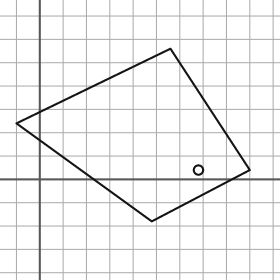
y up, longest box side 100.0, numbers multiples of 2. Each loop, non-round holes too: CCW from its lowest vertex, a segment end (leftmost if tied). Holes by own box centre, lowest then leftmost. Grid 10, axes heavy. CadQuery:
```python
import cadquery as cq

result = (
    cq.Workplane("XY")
    .moveTo(48.0, -18.0)
    .lineTo(90.0, 4.0)
    .lineTo(56.0, 56.0)
    .lineTo(-10.0, 24.0)
    .close()
    .moveTo(68.0, 4.0)
    .circle(2.0)
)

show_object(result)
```